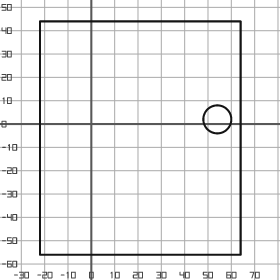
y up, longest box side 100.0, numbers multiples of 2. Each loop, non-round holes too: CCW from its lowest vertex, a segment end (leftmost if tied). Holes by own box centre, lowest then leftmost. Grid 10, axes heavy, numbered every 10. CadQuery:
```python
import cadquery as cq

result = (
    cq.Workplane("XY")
    .moveTo(-22.0, -56.0)
    .lineTo(64.0, -56.0)
    .lineTo(64.0, 44.0)
    .lineTo(-22.0, 44.0)
    .close()
    .moveTo(54.0, 2.0)
    .circle(6.0)
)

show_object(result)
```